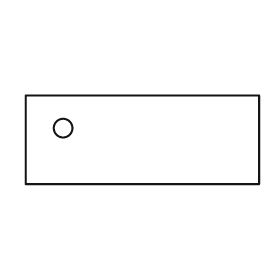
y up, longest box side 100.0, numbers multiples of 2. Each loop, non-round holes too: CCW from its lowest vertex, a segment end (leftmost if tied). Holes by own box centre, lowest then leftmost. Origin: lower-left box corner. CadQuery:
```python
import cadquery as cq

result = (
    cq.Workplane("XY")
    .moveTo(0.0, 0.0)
    .lineTo(100.0, 0.0)
    .lineTo(100.0, 38.0)
    .lineTo(0.0, 38.0)
    .close()
    .moveTo(16.0, 24.0)
    .circle(4.0)
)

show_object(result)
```